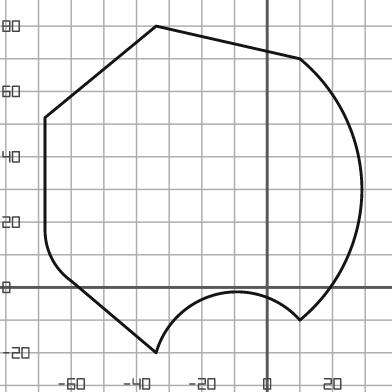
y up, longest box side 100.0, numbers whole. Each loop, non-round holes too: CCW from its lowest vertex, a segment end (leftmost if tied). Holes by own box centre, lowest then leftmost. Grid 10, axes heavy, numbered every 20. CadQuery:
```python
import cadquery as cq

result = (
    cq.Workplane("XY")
    .moveTo(-34.0, -20.0)
    .threePointArc((-15.0, -2.0), (10.0, -10.0))
    .threePointArc((24.0, 8.0), (29.0, 30.0))
    .threePointArc((24.0, 52.0), (10.0, 70.0))
    .lineTo(-34.0, 80.0)
    .lineTo(-68.0, 52.0)
    .lineTo(-68.0, 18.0)
    .threePointArc((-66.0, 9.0), (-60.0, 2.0))
    .close()
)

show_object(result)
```